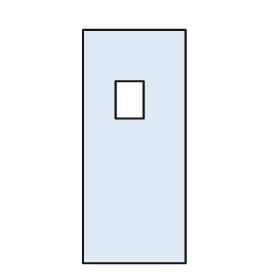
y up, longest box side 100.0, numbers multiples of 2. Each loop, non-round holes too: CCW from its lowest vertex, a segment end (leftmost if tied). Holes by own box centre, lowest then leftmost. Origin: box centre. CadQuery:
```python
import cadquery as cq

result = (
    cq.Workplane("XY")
    .moveTo(-22.0, -50.0)
    .lineTo(22.0, -50.0)
    .lineTo(22.0, 50.0)
    .lineTo(-22.0, 50.0)
    .close()
    .moveTo(-8.0, 12.0)
    .lineTo(4.0, 12.0)
    .lineTo(4.0, 28.0)
    .lineTo(-8.0, 28.0)
    .close()
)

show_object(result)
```